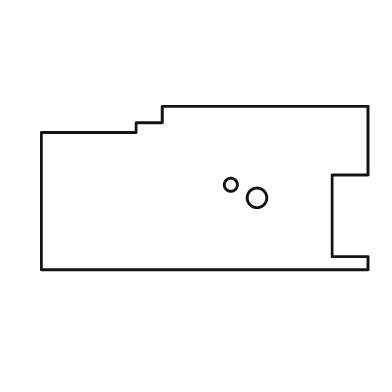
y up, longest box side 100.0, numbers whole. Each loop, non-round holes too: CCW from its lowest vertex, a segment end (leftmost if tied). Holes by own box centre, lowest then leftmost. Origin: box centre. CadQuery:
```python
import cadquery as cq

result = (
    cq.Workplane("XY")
    .moveTo(-50.0, -25.0)
    .lineTo(50.0, -25.0)
    .lineTo(50.0, -21.0)
    .lineTo(39.0, -21.0)
    .lineTo(39.0, 4.0)
    .lineTo(50.0, 4.0)
    .lineTo(50.0, 25.0)
    .lineTo(-13.0, 25.0)
    .lineTo(-13.0, 20.0)
    .lineTo(-21.0, 20.0)
    .lineTo(-21.0, 17.0)
    .lineTo(-50.0, 17.0)
    .close()
    .moveTo(16.0, -3.0)
    .circle(3.0)
    .moveTo(8.0, 1.0)
    .circle(2.0)
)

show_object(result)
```